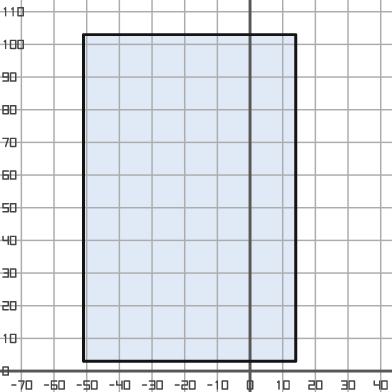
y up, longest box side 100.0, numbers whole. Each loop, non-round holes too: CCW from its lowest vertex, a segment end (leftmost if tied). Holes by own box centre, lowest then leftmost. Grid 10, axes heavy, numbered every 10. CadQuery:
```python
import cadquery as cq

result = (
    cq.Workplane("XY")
    .moveTo(-51.0, 3.0)
    .lineTo(14.0, 3.0)
    .lineTo(14.0, 103.0)
    .lineTo(-51.0, 103.0)
    .close()
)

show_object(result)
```